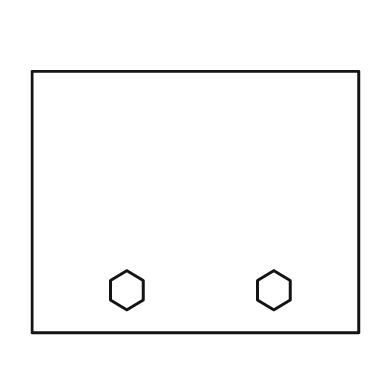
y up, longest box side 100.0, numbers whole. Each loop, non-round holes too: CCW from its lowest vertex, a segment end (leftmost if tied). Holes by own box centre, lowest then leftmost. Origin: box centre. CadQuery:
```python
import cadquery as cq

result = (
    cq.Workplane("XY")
    .moveTo(-50.0, -40.0)
    .lineTo(50.0, -40.0)
    .lineTo(50.0, 40.0)
    .lineTo(-50.0, 40.0)
    .close()
    .moveTo(-21.0, -33.0)
    .lineTo(-16.0, -30.0)
    .lineTo(-16.0, -24.0)
    .lineTo(-21.0, -21.0)
    .lineTo(-26.0, -24.0)
    .lineTo(-26.0, -30.0)
    .close()
    .moveTo(24.0, -33.0)
    .lineTo(29.0, -30.0)
    .lineTo(29.0, -24.0)
    .lineTo(24.0, -21.0)
    .lineTo(19.0, -24.0)
    .lineTo(19.0, -30.0)
    .close()
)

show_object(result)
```